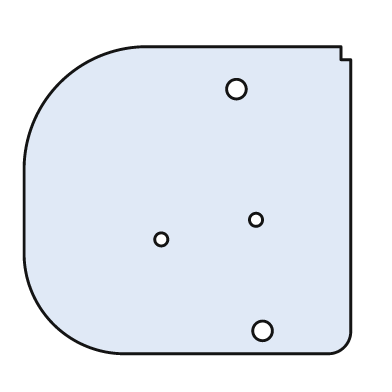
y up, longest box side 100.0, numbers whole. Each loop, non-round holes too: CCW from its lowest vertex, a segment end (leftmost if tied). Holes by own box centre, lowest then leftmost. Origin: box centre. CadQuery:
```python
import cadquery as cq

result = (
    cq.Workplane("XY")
    .moveTo(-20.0, -47.0)
    .lineTo(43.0, -47.0)
    .threePointArc((48.0, -45.0), (50.0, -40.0))
    .lineTo(50.0, 43.0)
    .lineTo(47.0, 43.0)
    .lineTo(47.0, 47.0)
    .lineTo(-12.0, 47.0)
    .threePointArc((-39.0, 36.0), (-50.0, 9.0))
    .lineTo(-50.0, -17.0)
    .threePointArc((-41.0, -38.0), (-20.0, -47.0))
    .close()
    .moveTo(23.0, -40.0)
    .circle(3.0)
    .moveTo(-8.0, -12.0)
    .circle(2.0)
    .moveTo(21.0, -6.0)
    .circle(2.0)
    .moveTo(15.0, 34.0)
    .circle(3.0)
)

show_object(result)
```